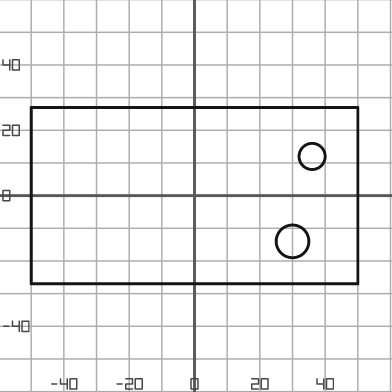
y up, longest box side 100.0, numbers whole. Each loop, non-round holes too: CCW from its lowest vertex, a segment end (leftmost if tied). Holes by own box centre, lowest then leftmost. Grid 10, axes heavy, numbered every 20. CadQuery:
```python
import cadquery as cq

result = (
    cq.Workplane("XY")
    .moveTo(-50.0, -27.0)
    .lineTo(50.0, -27.0)
    .lineTo(50.0, 27.0)
    .lineTo(-50.0, 27.0)
    .close()
    .moveTo(30.0, -14.0)
    .circle(5.0)
    .moveTo(36.0, 12.0)
    .circle(4.0)
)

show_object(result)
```